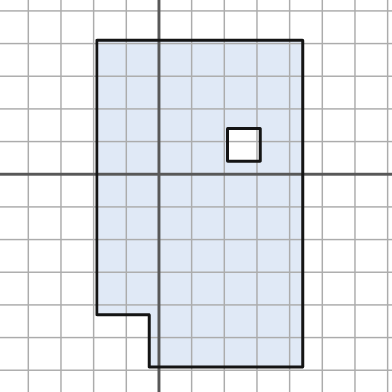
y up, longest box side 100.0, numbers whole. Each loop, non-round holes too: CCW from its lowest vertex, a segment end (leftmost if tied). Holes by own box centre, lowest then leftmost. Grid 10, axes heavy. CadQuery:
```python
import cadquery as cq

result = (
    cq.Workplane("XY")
    .moveTo(-3.0, -59.0)
    .lineTo(44.0, -59.0)
    .lineTo(44.0, 41.0)
    .lineTo(-19.0, 41.0)
    .lineTo(-19.0, -43.0)
    .lineTo(-3.0, -43.0)
    .close()
    .moveTo(21.0, 4.0)
    .lineTo(31.0, 4.0)
    .lineTo(31.0, 14.0)
    .lineTo(21.0, 14.0)
    .close()
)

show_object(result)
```